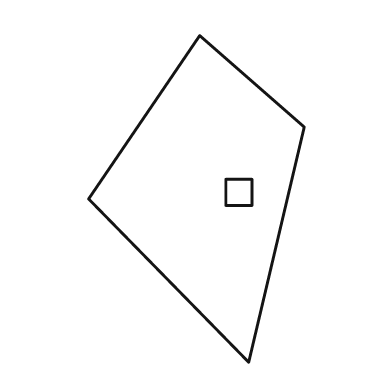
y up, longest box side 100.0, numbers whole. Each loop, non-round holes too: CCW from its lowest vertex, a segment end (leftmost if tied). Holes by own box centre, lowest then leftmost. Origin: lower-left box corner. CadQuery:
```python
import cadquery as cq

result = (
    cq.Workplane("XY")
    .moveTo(49.0, 0.0)
    .lineTo(66.0, 72.0)
    .lineTo(34.0, 100.0)
    .lineTo(0.0, 50.0)
    .close()
    .moveTo(42.0, 48.0)
    .lineTo(50.0, 48.0)
    .lineTo(50.0, 56.0)
    .lineTo(42.0, 56.0)
    .close()
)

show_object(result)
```